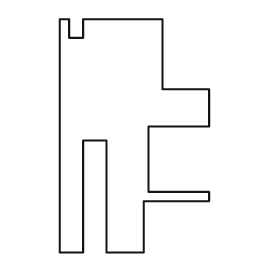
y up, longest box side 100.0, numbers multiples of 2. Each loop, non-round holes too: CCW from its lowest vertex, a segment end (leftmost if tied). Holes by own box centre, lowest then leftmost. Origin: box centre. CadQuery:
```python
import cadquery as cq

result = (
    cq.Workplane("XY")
    .moveTo(-32.0, -50.0)
    .lineTo(-22.0, -50.0)
    .lineTo(-22.0, -2.0)
    .lineTo(-12.0, -2.0)
    .lineTo(-12.0, -50.0)
    .lineTo(4.0, -50.0)
    .lineTo(4.0, -28.0)
    .lineTo(32.0, -28.0)
    .lineTo(32.0, -24.0)
    .lineTo(6.0, -24.0)
    .lineTo(6.0, 4.0)
    .lineTo(32.0, 4.0)
    .lineTo(32.0, 20.0)
    .lineTo(12.0, 20.0)
    .lineTo(12.0, 50.0)
    .lineTo(-22.0, 50.0)
    .lineTo(-22.0, 42.0)
    .lineTo(-28.0, 42.0)
    .lineTo(-28.0, 50.0)
    .lineTo(-32.0, 50.0)
    .close()
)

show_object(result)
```